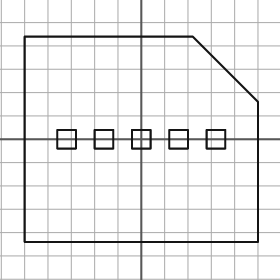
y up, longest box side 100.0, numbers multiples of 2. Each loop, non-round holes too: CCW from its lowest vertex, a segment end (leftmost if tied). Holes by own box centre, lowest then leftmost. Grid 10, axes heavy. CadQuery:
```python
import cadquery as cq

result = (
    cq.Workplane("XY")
    .moveTo(-50.0, -44.0)
    .lineTo(50.0, -44.0)
    .lineTo(50.0, 16.0)
    .lineTo(22.0, 44.0)
    .lineTo(-50.0, 44.0)
    .close()
    .moveTo(-36.0, -4.0)
    .lineTo(-28.0, -4.0)
    .lineTo(-28.0, 4.0)
    .lineTo(-36.0, 4.0)
    .close()
    .moveTo(-20.0, -4.0)
    .lineTo(-12.0, -4.0)
    .lineTo(-12.0, 4.0)
    .lineTo(-20.0, 4.0)
    .close()
    .moveTo(-4.0, -4.0)
    .lineTo(4.0, -4.0)
    .lineTo(4.0, 4.0)
    .lineTo(-4.0, 4.0)
    .close()
    .moveTo(12.0, -4.0)
    .lineTo(20.0, -4.0)
    .lineTo(20.0, 4.0)
    .lineTo(12.0, 4.0)
    .close()
    .moveTo(28.0, -4.0)
    .lineTo(36.0, -4.0)
    .lineTo(36.0, 4.0)
    .lineTo(28.0, 4.0)
    .close()
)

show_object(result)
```